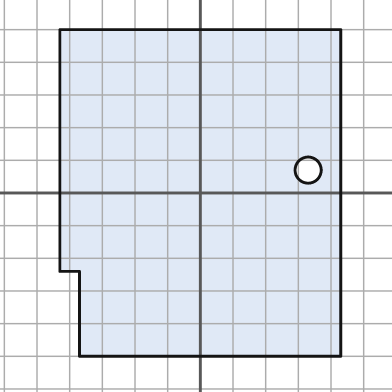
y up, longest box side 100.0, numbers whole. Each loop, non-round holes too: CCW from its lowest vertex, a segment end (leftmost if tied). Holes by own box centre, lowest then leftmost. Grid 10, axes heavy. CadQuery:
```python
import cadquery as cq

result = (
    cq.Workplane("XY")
    .moveTo(-37.0, -50.0)
    .lineTo(43.0, -50.0)
    .lineTo(43.0, 50.0)
    .lineTo(-43.0, 50.0)
    .lineTo(-43.0, -24.0)
    .lineTo(-37.0, -24.0)
    .close()
    .moveTo(33.0, 7.0)
    .circle(4.0)
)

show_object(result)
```